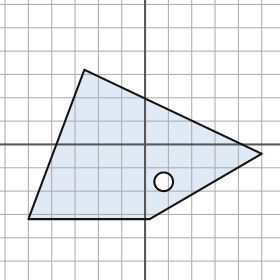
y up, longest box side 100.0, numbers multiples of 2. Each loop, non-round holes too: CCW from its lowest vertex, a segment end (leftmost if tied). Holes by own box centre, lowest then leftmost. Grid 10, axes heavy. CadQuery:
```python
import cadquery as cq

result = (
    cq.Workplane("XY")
    .moveTo(-50.0, -32.0)
    .lineTo(2.0, -32.0)
    .lineTo(50.0, -4.0)
    .lineTo(-26.0, 32.0)
    .close()
    .moveTo(8.0, -16.0)
    .circle(4.0)
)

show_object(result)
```